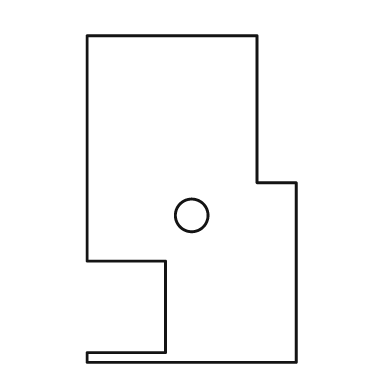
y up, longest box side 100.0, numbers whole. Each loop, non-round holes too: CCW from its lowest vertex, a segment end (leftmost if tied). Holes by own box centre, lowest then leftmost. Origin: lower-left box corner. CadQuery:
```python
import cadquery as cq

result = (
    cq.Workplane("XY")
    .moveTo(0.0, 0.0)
    .lineTo(64.0, 0.0)
    .lineTo(64.0, 55.0)
    .lineTo(52.0, 55.0)
    .lineTo(52.0, 100.0)
    .lineTo(0.0, 100.0)
    .lineTo(0.0, 31.0)
    .lineTo(24.0, 31.0)
    .lineTo(24.0, 3.0)
    .lineTo(0.0, 3.0)
    .close()
    .moveTo(32.0, 45.0)
    .circle(5.0)
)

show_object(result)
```